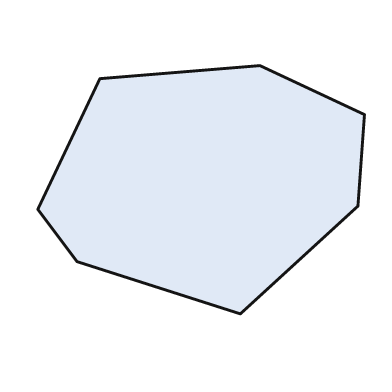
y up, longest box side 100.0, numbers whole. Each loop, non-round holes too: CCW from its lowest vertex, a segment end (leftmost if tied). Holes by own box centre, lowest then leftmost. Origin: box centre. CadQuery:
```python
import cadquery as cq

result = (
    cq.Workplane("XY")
    .moveTo(12.0, -38.0)
    .lineTo(48.0, -5.0)
    .lineTo(50.0, 23.0)
    .lineTo(18.0, 38.0)
    .lineTo(-31.0, 34.0)
    .lineTo(-50.0, -6.0)
    .lineTo(-38.0, -22.0)
    .close()
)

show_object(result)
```